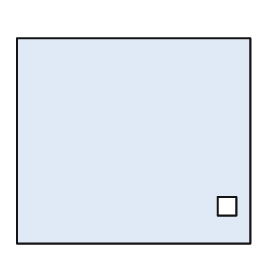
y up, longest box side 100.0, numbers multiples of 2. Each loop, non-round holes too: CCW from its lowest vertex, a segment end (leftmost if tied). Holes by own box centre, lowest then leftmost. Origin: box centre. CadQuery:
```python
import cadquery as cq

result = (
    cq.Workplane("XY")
    .moveTo(-50.0, -44.0)
    .lineTo(50.0, -44.0)
    .lineTo(50.0, 44.0)
    .lineTo(-50.0, 44.0)
    .close()
    .moveTo(36.0, -32.0)
    .lineTo(44.0, -32.0)
    .lineTo(44.0, -24.0)
    .lineTo(36.0, -24.0)
    .close()
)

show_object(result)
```